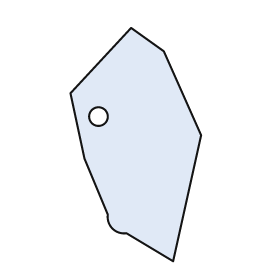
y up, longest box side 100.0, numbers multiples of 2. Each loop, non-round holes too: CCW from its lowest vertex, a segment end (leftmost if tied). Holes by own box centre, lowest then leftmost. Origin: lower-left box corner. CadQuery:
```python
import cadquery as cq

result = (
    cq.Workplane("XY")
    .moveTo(44.0, 0.0)
    .lineTo(56.0, 54.0)
    .lineTo(40.0, 90.0)
    .lineTo(26.0, 100.0)
    .lineTo(0.0, 72.0)
    .lineTo(6.0, 44.0)
    .lineTo(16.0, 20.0)
    .threePointArc((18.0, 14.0), (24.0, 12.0))
    .close()
    .moveTo(12.0, 62.0)
    .circle(4.0)
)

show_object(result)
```